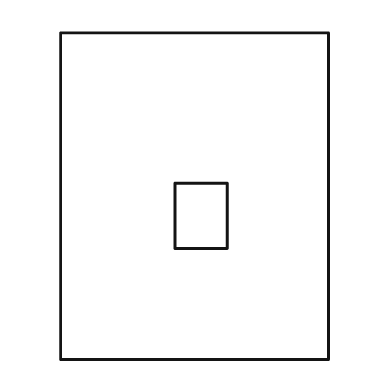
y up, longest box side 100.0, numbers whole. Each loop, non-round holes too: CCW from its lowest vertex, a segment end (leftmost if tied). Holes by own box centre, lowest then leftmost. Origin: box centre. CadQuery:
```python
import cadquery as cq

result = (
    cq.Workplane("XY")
    .moveTo(-41.0, -50.0)
    .lineTo(41.0, -50.0)
    .lineTo(41.0, 50.0)
    .lineTo(-41.0, 50.0)
    .close()
    .moveTo(-6.0, -16.0)
    .lineTo(10.0, -16.0)
    .lineTo(10.0, 4.0)
    .lineTo(-6.0, 4.0)
    .close()
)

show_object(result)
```